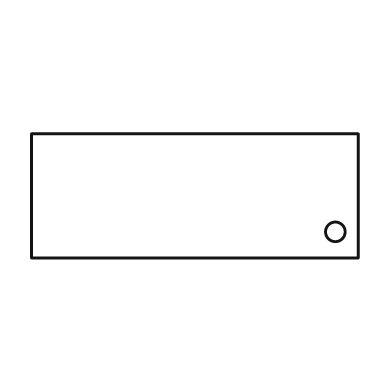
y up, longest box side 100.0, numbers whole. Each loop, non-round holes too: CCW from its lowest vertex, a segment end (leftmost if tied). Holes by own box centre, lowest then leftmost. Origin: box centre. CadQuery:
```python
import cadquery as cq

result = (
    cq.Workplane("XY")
    .moveTo(-50.0, -19.0)
    .lineTo(50.0, -19.0)
    .lineTo(50.0, 19.0)
    .lineTo(-50.0, 19.0)
    .close()
    .moveTo(43.0, -11.0)
    .circle(3.0)
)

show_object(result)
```